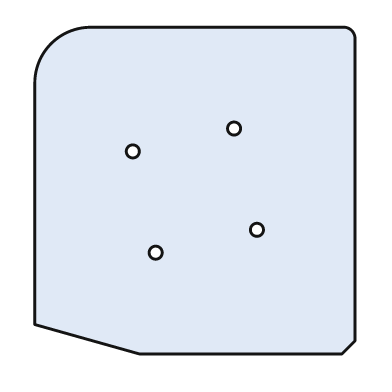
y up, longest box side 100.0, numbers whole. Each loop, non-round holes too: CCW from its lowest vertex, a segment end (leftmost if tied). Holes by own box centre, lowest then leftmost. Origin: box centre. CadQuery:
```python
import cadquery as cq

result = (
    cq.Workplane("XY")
    .moveTo(-17.0, -50.0)
    .lineTo(45.0, -50.0)
    .lineTo(49.0, -46.0)
    .lineTo(49.0, 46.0)
    .threePointArc((48.0, 49.0), (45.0, 50.0))
    .lineTo(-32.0, 50.0)
    .threePointArc((-44.0, 45.0), (-49.0, 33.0))
    .lineTo(-49.0, -41.0)
    .close()
    .moveTo(-12.0, -19.0)
    .circle(2.0)
    .moveTo(19.0, -12.0)
    .circle(2.0)
    .moveTo(-19.0, 12.0)
    .circle(2.0)
    .moveTo(12.0, 19.0)
    .circle(2.0)
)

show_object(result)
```